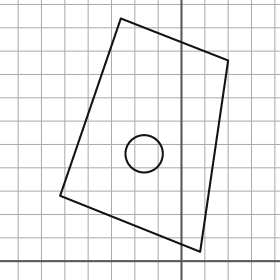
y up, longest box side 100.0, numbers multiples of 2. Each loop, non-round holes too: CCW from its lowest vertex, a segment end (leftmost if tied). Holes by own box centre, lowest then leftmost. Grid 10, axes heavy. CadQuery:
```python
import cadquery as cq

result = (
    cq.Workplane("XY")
    .moveTo(8.0, 4.0)
    .lineTo(20.0, 86.0)
    .lineTo(-26.0, 104.0)
    .lineTo(-52.0, 28.0)
    .close()
    .moveTo(-16.0, 46.0)
    .circle(8.0)
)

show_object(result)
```